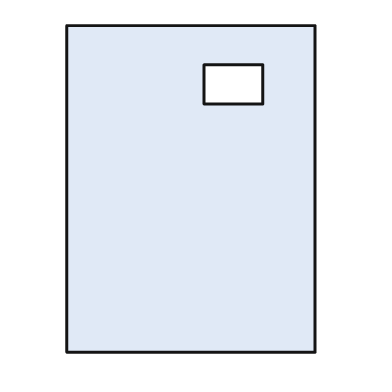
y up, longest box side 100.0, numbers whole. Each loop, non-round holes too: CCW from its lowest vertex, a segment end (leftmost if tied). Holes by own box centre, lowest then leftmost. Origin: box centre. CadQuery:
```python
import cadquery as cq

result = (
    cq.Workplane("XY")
    .moveTo(-38.0, -50.0)
    .lineTo(38.0, -50.0)
    .lineTo(38.0, 50.0)
    .lineTo(-38.0, 50.0)
    .close()
    .moveTo(4.0, 26.0)
    .lineTo(22.0, 26.0)
    .lineTo(22.0, 38.0)
    .lineTo(4.0, 38.0)
    .close()
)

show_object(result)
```